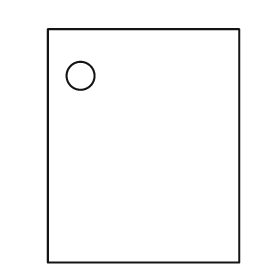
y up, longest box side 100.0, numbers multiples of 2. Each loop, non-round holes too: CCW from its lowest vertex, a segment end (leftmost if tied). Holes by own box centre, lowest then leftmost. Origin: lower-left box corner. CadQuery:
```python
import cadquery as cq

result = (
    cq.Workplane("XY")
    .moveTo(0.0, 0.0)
    .lineTo(82.0, 0.0)
    .lineTo(82.0, 100.0)
    .lineTo(0.0, 100.0)
    .close()
    .moveTo(14.0, 80.0)
    .circle(6.0)
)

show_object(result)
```